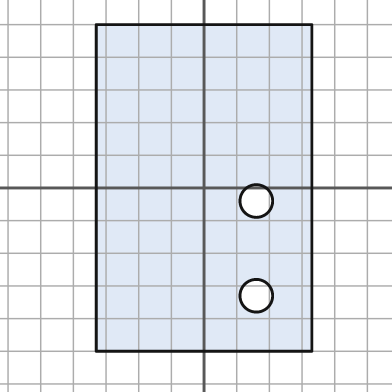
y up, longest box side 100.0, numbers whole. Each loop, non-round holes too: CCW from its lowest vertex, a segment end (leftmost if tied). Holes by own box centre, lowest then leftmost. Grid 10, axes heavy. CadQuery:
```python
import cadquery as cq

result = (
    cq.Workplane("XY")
    .moveTo(-33.0, -50.0)
    .lineTo(33.0, -50.0)
    .lineTo(33.0, 50.0)
    .lineTo(-33.0, 50.0)
    .close()
    .moveTo(16.0, -33.0)
    .circle(5.0)
    .moveTo(16.0, -4.0)
    .circle(5.0)
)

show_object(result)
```